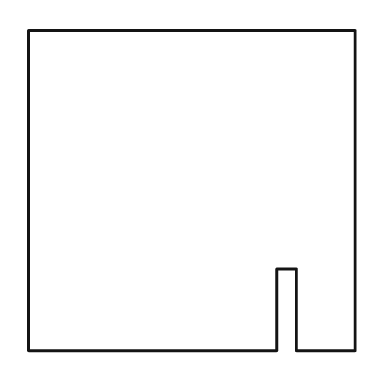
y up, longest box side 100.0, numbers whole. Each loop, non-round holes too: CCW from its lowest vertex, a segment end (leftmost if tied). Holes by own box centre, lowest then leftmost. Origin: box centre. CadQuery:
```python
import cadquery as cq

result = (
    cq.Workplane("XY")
    .moveTo(-50.0, -49.0)
    .lineTo(26.0, -49.0)
    .lineTo(26.0, -24.0)
    .lineTo(32.0, -24.0)
    .lineTo(32.0, -49.0)
    .lineTo(50.0, -49.0)
    .lineTo(50.0, 49.0)
    .lineTo(-50.0, 49.0)
    .close()
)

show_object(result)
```